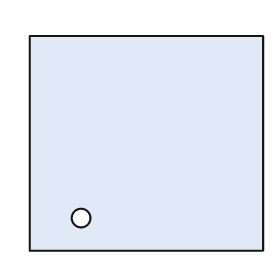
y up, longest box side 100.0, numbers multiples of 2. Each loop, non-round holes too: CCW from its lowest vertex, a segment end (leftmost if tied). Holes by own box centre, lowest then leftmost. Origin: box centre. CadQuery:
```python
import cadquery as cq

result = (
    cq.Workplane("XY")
    .moveTo(-50.0, -46.0)
    .lineTo(50.0, -46.0)
    .lineTo(50.0, 46.0)
    .lineTo(-50.0, 46.0)
    .close()
    .moveTo(-28.0, -32.0)
    .circle(4.0)
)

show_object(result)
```